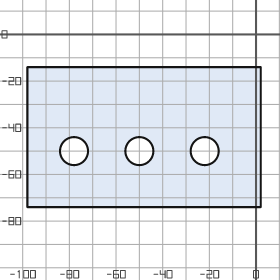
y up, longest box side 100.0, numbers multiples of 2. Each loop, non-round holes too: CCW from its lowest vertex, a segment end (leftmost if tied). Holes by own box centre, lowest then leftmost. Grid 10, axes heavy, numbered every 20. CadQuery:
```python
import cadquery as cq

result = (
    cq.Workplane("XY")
    .moveTo(-98.0, -74.0)
    .lineTo(2.0, -74.0)
    .lineTo(2.0, -14.0)
    .lineTo(-98.0, -14.0)
    .close()
    .moveTo(-78.0, -50.0)
    .circle(6.0)
    .moveTo(-50.0, -50.0)
    .circle(6.0)
    .moveTo(-22.0, -50.0)
    .circle(6.0)
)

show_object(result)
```